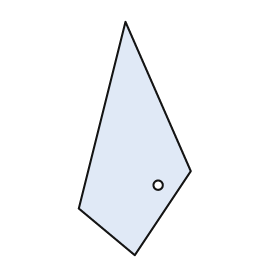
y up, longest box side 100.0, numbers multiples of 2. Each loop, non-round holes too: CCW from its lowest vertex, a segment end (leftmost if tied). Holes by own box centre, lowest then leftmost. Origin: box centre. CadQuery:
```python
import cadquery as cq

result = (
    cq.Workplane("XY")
    .moveTo(0.0, -50.0)
    .lineTo(24.0, -14.0)
    .lineTo(-4.0, 50.0)
    .lineTo(-24.0, -30.0)
    .close()
    .moveTo(10.0, -20.0)
    .circle(2.0)
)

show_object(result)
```